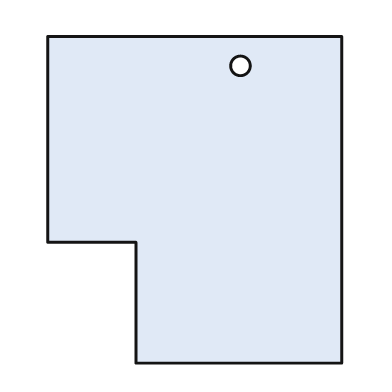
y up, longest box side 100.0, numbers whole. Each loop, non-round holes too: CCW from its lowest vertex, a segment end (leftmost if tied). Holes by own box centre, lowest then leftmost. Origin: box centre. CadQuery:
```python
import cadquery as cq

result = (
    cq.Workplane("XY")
    .moveTo(-18.0, -50.0)
    .lineTo(45.0, -50.0)
    .lineTo(45.0, 50.0)
    .lineTo(-45.0, 50.0)
    .lineTo(-45.0, -13.0)
    .lineTo(-18.0, -13.0)
    .close()
    .moveTo(14.0, 41.0)
    .circle(3.0)
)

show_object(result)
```